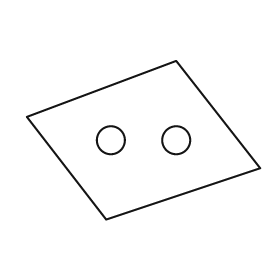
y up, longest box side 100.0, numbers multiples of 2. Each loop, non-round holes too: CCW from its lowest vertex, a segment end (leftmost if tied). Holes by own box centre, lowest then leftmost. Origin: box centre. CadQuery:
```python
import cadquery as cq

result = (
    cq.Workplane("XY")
    .moveTo(-16.0, -34.0)
    .lineTo(50.0, -12.0)
    .lineTo(14.0, 34.0)
    .lineTo(-50.0, 10.0)
    .close()
    .moveTo(-14.0, 0.0)
    .circle(6.0)
    .moveTo(14.0, 0.0)
    .circle(6.0)
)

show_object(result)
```